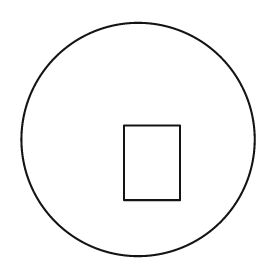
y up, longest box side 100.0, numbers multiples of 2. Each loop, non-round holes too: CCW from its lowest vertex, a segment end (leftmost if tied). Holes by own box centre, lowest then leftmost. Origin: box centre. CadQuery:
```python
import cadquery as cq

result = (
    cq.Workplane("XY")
    .moveTo(0.0, 0.0)
    .circle(50.0)
    .moveTo(-6.0, -26.0)
    .lineTo(18.0, -26.0)
    .lineTo(18.0, 6.0)
    .lineTo(-6.0, 6.0)
    .close()
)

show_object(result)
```